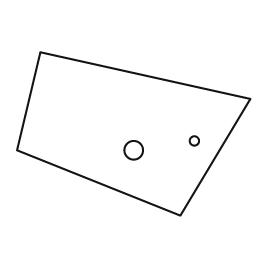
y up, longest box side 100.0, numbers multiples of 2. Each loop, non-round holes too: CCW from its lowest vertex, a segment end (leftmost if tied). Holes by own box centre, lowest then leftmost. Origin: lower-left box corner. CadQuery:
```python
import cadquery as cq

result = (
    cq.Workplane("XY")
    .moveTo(70.0, 0.0)
    .lineTo(100.0, 50.0)
    .lineTo(10.0, 70.0)
    .lineTo(0.0, 28.0)
    .close()
    .moveTo(50.0, 28.0)
    .circle(4.0)
    .moveTo(76.0, 32.0)
    .circle(2.0)
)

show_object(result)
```